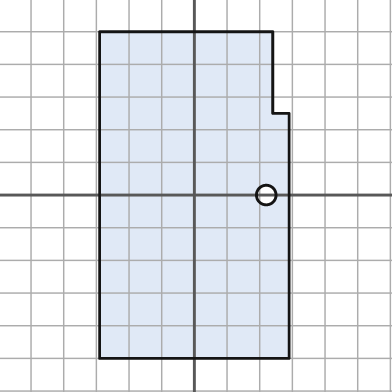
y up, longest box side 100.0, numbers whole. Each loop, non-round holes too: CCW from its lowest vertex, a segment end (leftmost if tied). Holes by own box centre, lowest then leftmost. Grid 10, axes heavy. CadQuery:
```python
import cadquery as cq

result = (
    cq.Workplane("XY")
    .moveTo(-29.0, -50.0)
    .lineTo(29.0, -50.0)
    .lineTo(29.0, 25.0)
    .lineTo(24.0, 25.0)
    .lineTo(24.0, 50.0)
    .lineTo(-29.0, 50.0)
    .close()
    .moveTo(22.0, 0.0)
    .circle(3.0)
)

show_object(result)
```